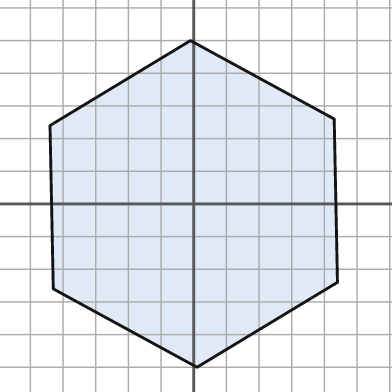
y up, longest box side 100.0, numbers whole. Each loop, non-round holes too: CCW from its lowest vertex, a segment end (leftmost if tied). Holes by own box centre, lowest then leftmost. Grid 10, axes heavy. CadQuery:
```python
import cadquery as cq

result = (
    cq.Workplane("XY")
    .moveTo(1.0, -50.0)
    .lineTo(44.0, -24.0)
    .lineTo(43.0, 26.0)
    .lineTo(-1.0, 50.0)
    .lineTo(-44.0, 24.0)
    .lineTo(-43.0, -26.0)
    .close()
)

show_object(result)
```